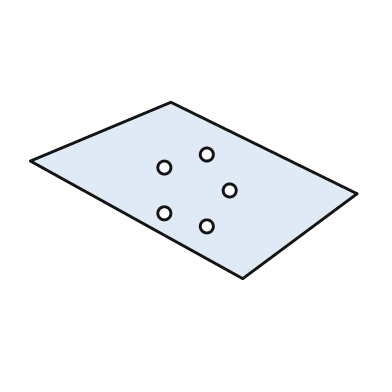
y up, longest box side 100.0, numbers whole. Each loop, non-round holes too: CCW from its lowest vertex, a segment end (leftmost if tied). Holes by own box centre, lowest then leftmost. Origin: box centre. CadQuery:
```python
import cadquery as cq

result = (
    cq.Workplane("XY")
    .moveTo(15.0, -27.0)
    .lineTo(50.0, -1.0)
    .lineTo(-7.0, 27.0)
    .lineTo(-50.0, 9.0)
    .close()
    .moveTo(4.0, -11.0)
    .circle(2.0)
    .moveTo(-9.0, -7.0)
    .circle(2.0)
    .moveTo(11.0, 0.0)
    .circle(2.0)
    .moveTo(-9.0, 7.0)
    .circle(2.0)
    .moveTo(4.0, 11.0)
    .circle(2.0)
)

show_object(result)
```